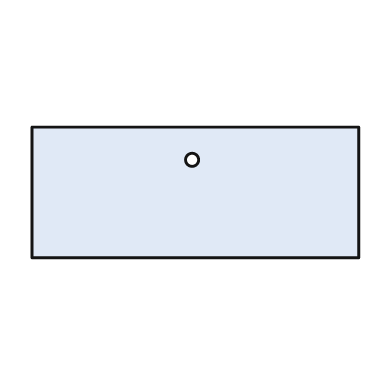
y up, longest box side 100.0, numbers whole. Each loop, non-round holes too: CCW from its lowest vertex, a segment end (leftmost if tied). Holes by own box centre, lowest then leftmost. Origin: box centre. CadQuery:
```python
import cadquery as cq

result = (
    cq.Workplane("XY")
    .moveTo(-50.0, -20.0)
    .lineTo(50.0, -20.0)
    .lineTo(50.0, 20.0)
    .lineTo(-50.0, 20.0)
    .close()
    .moveTo(-1.0, 10.0)
    .circle(2.0)
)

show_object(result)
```